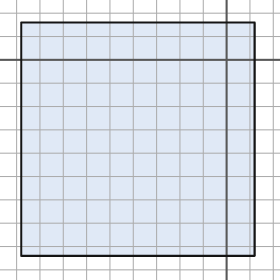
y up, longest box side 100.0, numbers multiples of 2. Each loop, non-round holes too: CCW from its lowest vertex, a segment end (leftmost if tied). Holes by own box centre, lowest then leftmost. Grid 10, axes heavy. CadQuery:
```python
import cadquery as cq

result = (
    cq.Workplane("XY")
    .moveTo(-88.0, -84.0)
    .lineTo(12.0, -84.0)
    .lineTo(12.0, 16.0)
    .lineTo(-88.0, 16.0)
    .close()
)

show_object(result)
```